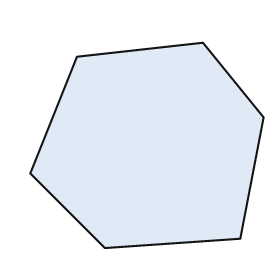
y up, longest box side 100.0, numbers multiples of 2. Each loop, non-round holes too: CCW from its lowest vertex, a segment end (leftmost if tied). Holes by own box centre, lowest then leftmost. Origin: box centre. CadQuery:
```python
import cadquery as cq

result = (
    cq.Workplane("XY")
    .moveTo(-18.0, -44.0)
    .lineTo(40.0, -40.0)
    .lineTo(50.0, 12.0)
    .lineTo(24.0, 44.0)
    .lineTo(-30.0, 38.0)
    .lineTo(-50.0, -12.0)
    .close()
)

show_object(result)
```